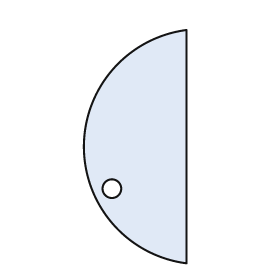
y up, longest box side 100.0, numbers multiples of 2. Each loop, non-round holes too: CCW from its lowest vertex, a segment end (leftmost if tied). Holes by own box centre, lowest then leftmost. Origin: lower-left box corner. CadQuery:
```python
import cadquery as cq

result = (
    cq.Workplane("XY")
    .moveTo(44.0, 0.0)
    .lineTo(44.0, 100.0)
    .threePointArc((0.0, 50.0), (44.0, 0.0))
    .close()
    .moveTo(12.0, 32.0)
    .circle(4.0)
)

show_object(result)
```